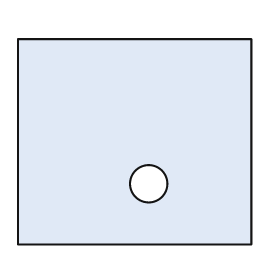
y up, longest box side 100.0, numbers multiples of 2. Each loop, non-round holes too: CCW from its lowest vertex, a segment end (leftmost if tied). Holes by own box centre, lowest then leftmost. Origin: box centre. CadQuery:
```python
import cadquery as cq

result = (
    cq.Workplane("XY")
    .moveTo(-50.0, -44.0)
    .lineTo(50.0, -44.0)
    .lineTo(50.0, 44.0)
    .lineTo(-50.0, 44.0)
    .close()
    .moveTo(6.0, -18.0)
    .circle(8.0)
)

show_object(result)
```